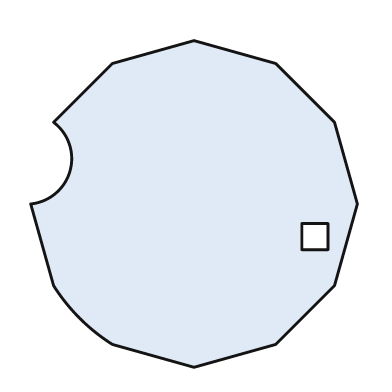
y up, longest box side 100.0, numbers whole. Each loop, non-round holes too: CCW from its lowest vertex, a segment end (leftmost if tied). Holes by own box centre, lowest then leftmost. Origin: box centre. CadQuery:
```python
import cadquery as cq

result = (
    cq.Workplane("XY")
    .moveTo(0.0, -50.0)
    .lineTo(25.0, -43.0)
    .lineTo(43.0, -25.0)
    .lineTo(50.0, 0.0)
    .lineTo(43.0, 25.0)
    .lineTo(25.0, 43.0)
    .lineTo(0.0, 50.0)
    .lineTo(-25.0, 43.0)
    .lineTo(-43.0, 25.0)
    .threePointArc((-38.0, 10.0), (-50.0, 0.0))
    .lineTo(-43.0, -25.0)
    .threePointArc((-35.0, -35.0), (-25.0, -43.0))
    .close()
    .moveTo(33.0, -14.0)
    .lineTo(41.0, -14.0)
    .lineTo(41.0, -6.0)
    .lineTo(33.0, -6.0)
    .close()
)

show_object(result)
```